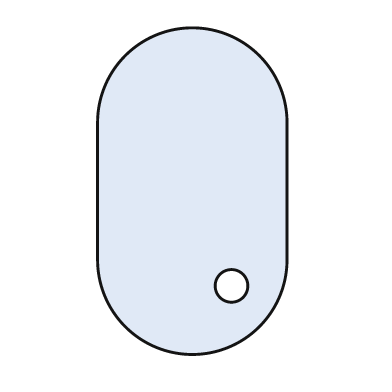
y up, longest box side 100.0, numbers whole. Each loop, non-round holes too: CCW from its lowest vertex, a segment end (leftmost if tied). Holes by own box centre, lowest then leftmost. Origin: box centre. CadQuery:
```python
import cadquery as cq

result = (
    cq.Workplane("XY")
    .moveTo(-29.0, -21.0)
    .threePointArc((0.0, -50.0), (29.0, -21.0))
    .lineTo(29.0, 21.0)
    .threePointArc((0.0, 50.0), (-29.0, 21.0))
    .close()
    .moveTo(12.0, -29.0)
    .circle(5.0)
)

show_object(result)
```